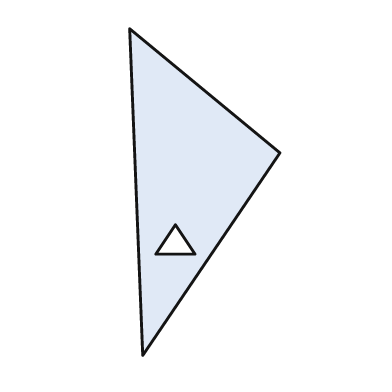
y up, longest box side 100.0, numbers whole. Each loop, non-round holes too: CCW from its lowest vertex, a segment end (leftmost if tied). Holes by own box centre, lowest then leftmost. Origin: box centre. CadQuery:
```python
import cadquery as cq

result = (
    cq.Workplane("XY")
    .moveTo(-19.0, -50.0)
    .lineTo(23.0, 12.0)
    .lineTo(-23.0, 50.0)
    .close()
    .moveTo(-15.0, -19.0)
    .lineTo(-3.0, -19.0)
    .lineTo(-9.0, -10.0)
    .close()
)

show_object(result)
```